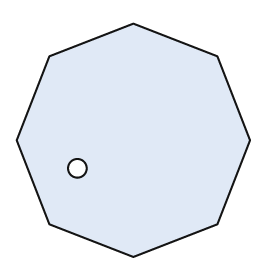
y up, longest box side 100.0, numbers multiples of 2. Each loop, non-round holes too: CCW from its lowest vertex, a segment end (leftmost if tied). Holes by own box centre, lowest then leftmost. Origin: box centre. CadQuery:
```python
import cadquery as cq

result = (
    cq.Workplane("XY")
    .moveTo(0.0, -50.0)
    .lineTo(36.0, -36.0)
    .lineTo(50.0, 0.0)
    .lineTo(36.0, 36.0)
    .lineTo(0.0, 50.0)
    .lineTo(-36.0, 36.0)
    .lineTo(-50.0, 0.0)
    .lineTo(-36.0, -36.0)
    .close()
    .moveTo(-24.0, -12.0)
    .circle(4.0)
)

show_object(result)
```